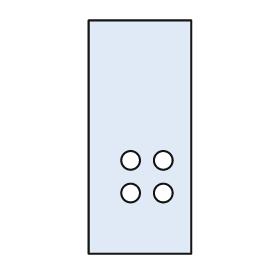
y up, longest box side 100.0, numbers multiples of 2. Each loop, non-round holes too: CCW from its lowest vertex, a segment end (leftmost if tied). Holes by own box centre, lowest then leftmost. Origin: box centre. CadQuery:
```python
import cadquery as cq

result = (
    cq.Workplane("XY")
    .moveTo(-22.0, -50.0)
    .lineTo(22.0, -50.0)
    .lineTo(22.0, 50.0)
    .lineTo(-22.0, 50.0)
    .close()
    .moveTo(-4.0, -24.0)
    .circle(4.0)
    .moveTo(10.0, -24.0)
    .circle(4.0)
    .moveTo(-4.0, -10.0)
    .circle(4.0)
    .moveTo(10.0, -10.0)
    .circle(4.0)
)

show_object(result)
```